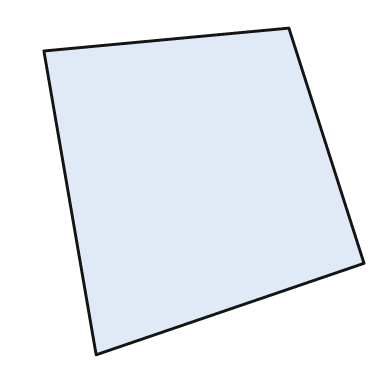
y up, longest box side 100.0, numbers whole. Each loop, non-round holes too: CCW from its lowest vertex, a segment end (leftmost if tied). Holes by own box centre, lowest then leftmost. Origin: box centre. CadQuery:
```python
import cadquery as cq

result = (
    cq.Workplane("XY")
    .moveTo(-33.0, -50.0)
    .lineTo(49.0, -22.0)
    .lineTo(26.0, 50.0)
    .lineTo(-49.0, 43.0)
    .close()
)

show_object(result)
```